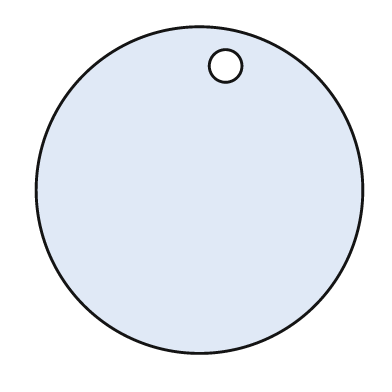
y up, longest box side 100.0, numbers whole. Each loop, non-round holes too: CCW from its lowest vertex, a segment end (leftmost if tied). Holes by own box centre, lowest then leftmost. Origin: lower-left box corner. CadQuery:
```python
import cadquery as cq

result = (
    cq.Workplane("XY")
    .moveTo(50.0, 50.0)
    .circle(50.0)
    .moveTo(58.0, 88.0)
    .circle(5.0)
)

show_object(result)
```